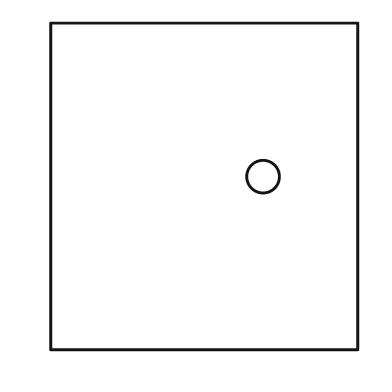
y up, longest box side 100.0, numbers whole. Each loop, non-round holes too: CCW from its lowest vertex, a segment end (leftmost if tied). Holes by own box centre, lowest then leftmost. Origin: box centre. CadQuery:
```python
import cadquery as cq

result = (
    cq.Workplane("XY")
    .moveTo(-47.0, -50.0)
    .lineTo(47.0, -50.0)
    .lineTo(47.0, 50.0)
    .lineTo(-47.0, 50.0)
    .close()
    .moveTo(18.0, 3.0)
    .circle(5.0)
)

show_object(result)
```